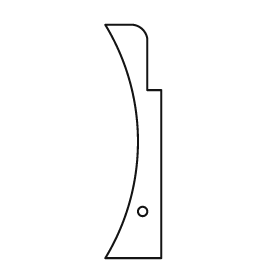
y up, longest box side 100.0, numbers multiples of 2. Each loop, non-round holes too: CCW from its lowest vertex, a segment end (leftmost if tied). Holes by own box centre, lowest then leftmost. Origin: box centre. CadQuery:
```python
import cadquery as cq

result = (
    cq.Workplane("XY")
    .moveTo(-12.0, -50.0)
    .lineTo(12.0, -50.0)
    .lineTo(12.0, 22.0)
    .lineTo(6.0, 22.0)
    .lineTo(6.0, 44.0)
    .threePointArc((4.0, 48.0), (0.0, 50.0))
    .lineTo(-12.0, 50.0)
    .threePointArc((2.0, 0.0), (-12.0, -50.0))
    .close()
    .moveTo(4.0, -30.0)
    .circle(2.0)
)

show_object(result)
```